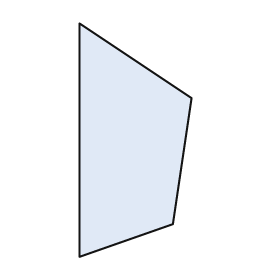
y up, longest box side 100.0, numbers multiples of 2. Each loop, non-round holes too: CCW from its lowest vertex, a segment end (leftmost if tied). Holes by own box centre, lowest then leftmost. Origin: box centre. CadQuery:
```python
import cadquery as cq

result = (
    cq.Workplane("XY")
    .moveTo(-24.0, -50.0)
    .lineTo(16.0, -36.0)
    .lineTo(24.0, 18.0)
    .lineTo(-24.0, 50.0)
    .close()
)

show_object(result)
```